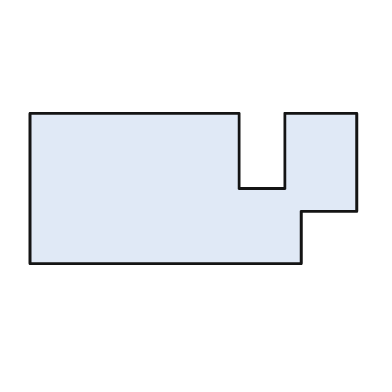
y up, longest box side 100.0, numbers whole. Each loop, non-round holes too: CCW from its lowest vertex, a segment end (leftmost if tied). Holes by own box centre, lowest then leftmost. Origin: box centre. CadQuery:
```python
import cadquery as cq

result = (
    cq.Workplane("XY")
    .moveTo(-50.0, -23.0)
    .lineTo(33.0, -23.0)
    .lineTo(33.0, -7.0)
    .lineTo(50.0, -7.0)
    .lineTo(50.0, 23.0)
    .lineTo(28.0, 23.0)
    .lineTo(28.0, 0.0)
    .lineTo(14.0, 0.0)
    .lineTo(14.0, 23.0)
    .lineTo(-50.0, 23.0)
    .close()
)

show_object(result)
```